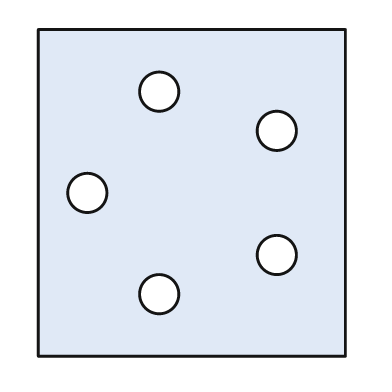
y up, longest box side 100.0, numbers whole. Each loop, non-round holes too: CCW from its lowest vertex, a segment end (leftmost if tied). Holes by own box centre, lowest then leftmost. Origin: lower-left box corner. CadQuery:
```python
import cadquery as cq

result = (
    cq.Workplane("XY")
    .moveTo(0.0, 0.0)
    .lineTo(94.0, 0.0)
    .lineTo(94.0, 100.0)
    .lineTo(0.0, 100.0)
    .close()
    .moveTo(37.0, 19.0)
    .circle(6.0)
    .moveTo(73.0, 31.0)
    .circle(6.0)
    .moveTo(15.0, 50.0)
    .circle(6.0)
    .moveTo(73.0, 69.0)
    .circle(6.0)
    .moveTo(37.0, 81.0)
    .circle(6.0)
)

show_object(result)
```